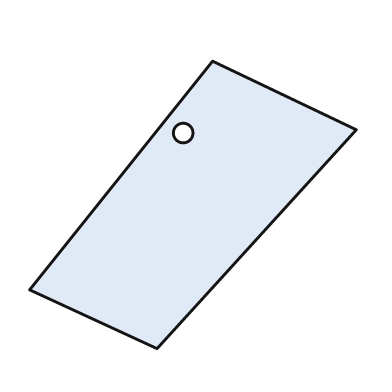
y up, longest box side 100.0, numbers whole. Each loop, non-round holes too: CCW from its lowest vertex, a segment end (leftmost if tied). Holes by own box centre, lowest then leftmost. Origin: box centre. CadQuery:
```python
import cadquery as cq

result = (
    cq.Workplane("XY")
    .moveTo(-11.0, -44.0)
    .lineTo(50.0, 23.0)
    .lineTo(6.0, 44.0)
    .lineTo(-50.0, -26.0)
    .close()
    .moveTo(-3.0, 22.0)
    .circle(3.0)
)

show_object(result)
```